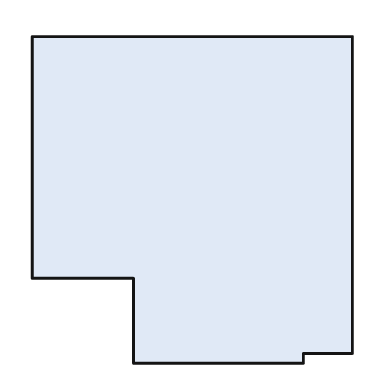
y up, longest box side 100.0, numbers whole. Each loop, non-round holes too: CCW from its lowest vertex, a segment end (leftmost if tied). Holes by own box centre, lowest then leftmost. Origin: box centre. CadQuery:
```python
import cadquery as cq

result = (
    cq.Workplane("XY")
    .moveTo(-18.0, -50.0)
    .lineTo(34.0, -50.0)
    .lineTo(34.0, -47.0)
    .lineTo(49.0, -47.0)
    .lineTo(49.0, 50.0)
    .lineTo(-49.0, 50.0)
    .lineTo(-49.0, -24.0)
    .lineTo(-18.0, -24.0)
    .close()
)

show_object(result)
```